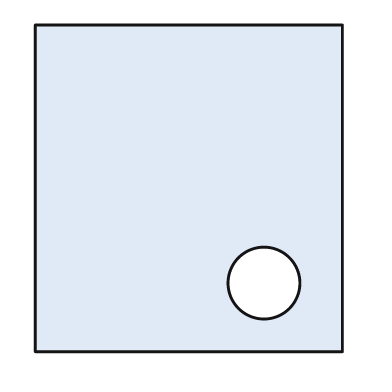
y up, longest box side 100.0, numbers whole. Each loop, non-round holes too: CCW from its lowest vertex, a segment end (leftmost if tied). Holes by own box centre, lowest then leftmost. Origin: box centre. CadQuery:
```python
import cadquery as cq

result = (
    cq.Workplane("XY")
    .moveTo(-47.0, -50.0)
    .lineTo(47.0, -50.0)
    .lineTo(47.0, 50.0)
    .lineTo(-47.0, 50.0)
    .close()
    .moveTo(23.0, -29.0)
    .circle(11.0)
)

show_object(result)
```